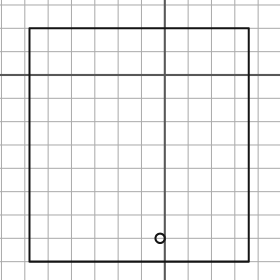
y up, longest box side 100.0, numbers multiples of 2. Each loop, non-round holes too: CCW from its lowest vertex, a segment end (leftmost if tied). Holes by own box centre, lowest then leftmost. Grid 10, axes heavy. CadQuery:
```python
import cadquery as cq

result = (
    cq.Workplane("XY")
    .moveTo(-58.0, -80.0)
    .lineTo(36.0, -80.0)
    .lineTo(36.0, 20.0)
    .lineTo(-58.0, 20.0)
    .close()
    .moveTo(-2.0, -70.0)
    .circle(2.0)
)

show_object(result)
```